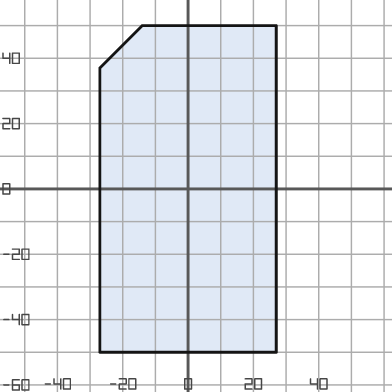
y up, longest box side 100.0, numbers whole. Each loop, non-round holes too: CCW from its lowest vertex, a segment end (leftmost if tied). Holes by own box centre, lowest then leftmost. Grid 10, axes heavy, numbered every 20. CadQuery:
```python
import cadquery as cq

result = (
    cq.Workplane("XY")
    .moveTo(-27.0, -50.0)
    .lineTo(27.0, -50.0)
    .lineTo(27.0, 50.0)
    .lineTo(-14.0, 50.0)
    .lineTo(-27.0, 37.0)
    .close()
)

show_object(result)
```